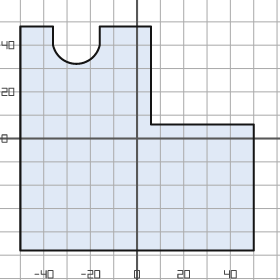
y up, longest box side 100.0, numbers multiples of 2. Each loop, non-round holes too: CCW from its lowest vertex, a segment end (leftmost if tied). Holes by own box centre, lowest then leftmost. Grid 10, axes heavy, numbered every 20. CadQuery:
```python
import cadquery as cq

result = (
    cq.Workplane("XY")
    .moveTo(-50.0, -48.0)
    .lineTo(50.0, -48.0)
    .lineTo(50.0, 6.0)
    .lineTo(6.0, 6.0)
    .lineTo(6.0, 48.0)
    .lineTo(-16.0, 48.0)
    .lineTo(-16.0, 40.0)
    .threePointArc((-26.0, 32.0), (-36.0, 40.0))
    .lineTo(-36.0, 48.0)
    .lineTo(-50.0, 48.0)
    .close()
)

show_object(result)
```